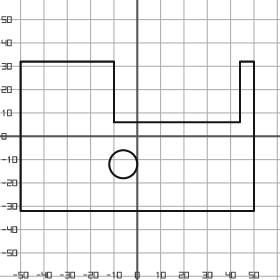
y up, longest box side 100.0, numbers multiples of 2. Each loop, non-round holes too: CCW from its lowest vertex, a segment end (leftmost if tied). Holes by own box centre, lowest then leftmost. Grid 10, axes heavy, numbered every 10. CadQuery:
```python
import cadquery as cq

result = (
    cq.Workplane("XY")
    .moveTo(-50.0, -32.0)
    .lineTo(50.0, -32.0)
    .lineTo(50.0, 32.0)
    .lineTo(44.0, 32.0)
    .lineTo(44.0, 6.0)
    .lineTo(-10.0, 6.0)
    .lineTo(-10.0, 32.0)
    .lineTo(-50.0, 32.0)
    .close()
    .moveTo(-6.0, -12.0)
    .circle(6.0)
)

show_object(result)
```